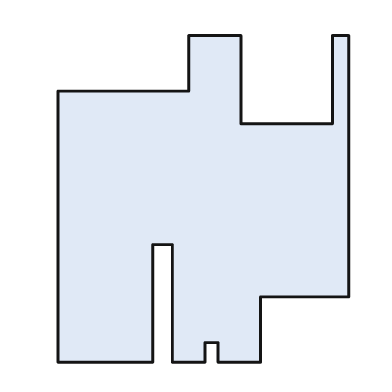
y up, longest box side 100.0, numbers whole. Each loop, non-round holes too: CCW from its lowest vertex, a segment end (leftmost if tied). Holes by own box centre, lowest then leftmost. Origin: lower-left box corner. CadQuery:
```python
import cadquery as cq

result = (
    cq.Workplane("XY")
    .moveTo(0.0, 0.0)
    .lineTo(29.0, 0.0)
    .lineTo(29.0, 36.0)
    .lineTo(35.0, 36.0)
    .lineTo(35.0, 0.0)
    .lineTo(45.0, 0.0)
    .lineTo(45.0, 6.0)
    .lineTo(49.0, 6.0)
    .lineTo(49.0, 0.0)
    .lineTo(62.0, 0.0)
    .lineTo(62.0, 20.0)
    .lineTo(89.0, 20.0)
    .lineTo(89.0, 100.0)
    .lineTo(84.0, 100.0)
    .lineTo(84.0, 73.0)
    .lineTo(56.0, 73.0)
    .lineTo(56.0, 100.0)
    .lineTo(40.0, 100.0)
    .lineTo(40.0, 83.0)
    .lineTo(0.0, 83.0)
    .close()
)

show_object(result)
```